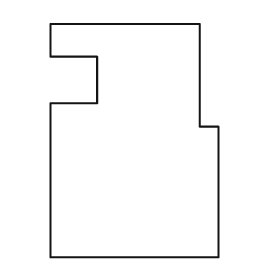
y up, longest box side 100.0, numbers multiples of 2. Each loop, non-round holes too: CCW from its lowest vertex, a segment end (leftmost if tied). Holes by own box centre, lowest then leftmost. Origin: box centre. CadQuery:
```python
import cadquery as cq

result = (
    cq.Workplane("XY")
    .moveTo(-36.0, -50.0)
    .lineTo(36.0, -50.0)
    .lineTo(36.0, 6.0)
    .lineTo(28.0, 6.0)
    .lineTo(28.0, 50.0)
    .lineTo(-36.0, 50.0)
    .lineTo(-36.0, 36.0)
    .lineTo(-16.0, 36.0)
    .lineTo(-16.0, 16.0)
    .lineTo(-36.0, 16.0)
    .close()
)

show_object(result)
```